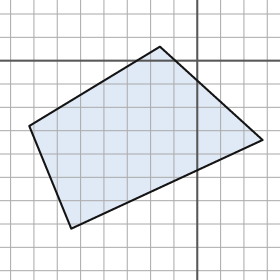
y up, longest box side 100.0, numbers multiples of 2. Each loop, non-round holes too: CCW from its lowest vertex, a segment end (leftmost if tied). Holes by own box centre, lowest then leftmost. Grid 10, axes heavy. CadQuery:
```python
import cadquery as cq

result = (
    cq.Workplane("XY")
    .moveTo(-54.0, -72.0)
    .lineTo(28.0, -34.0)
    .lineTo(-16.0, 6.0)
    .lineTo(-72.0, -28.0)
    .close()
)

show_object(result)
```